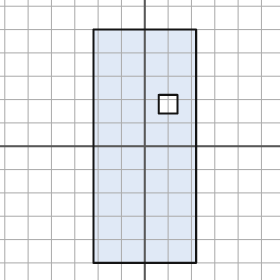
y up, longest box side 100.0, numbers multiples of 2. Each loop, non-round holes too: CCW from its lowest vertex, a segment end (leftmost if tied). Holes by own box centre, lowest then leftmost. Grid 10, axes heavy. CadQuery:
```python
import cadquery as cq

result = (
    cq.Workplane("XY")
    .moveTo(-22.0, -50.0)
    .lineTo(22.0, -50.0)
    .lineTo(22.0, 50.0)
    .lineTo(-22.0, 50.0)
    .close()
    .moveTo(6.0, 14.0)
    .lineTo(14.0, 14.0)
    .lineTo(14.0, 22.0)
    .lineTo(6.0, 22.0)
    .close()
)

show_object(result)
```